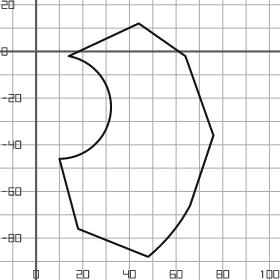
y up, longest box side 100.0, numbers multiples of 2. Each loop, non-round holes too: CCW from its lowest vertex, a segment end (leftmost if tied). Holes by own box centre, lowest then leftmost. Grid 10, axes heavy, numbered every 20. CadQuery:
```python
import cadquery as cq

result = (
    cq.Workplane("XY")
    .moveTo(48.0, -88.0)
    .threePointArc((58.0, -78.0), (66.0, -66.0))
    .lineTo(76.0, -36.0)
    .lineTo(64.0, -2.0)
    .lineTo(44.0, 12.0)
    .lineTo(14.0, -2.0)
    .threePointArc((32.0, -26.0), (10.0, -46.0))
    .lineTo(18.0, -76.0)
    .close()
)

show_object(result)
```